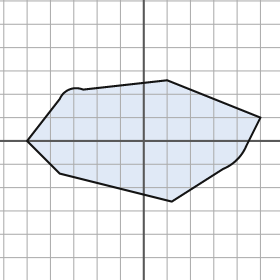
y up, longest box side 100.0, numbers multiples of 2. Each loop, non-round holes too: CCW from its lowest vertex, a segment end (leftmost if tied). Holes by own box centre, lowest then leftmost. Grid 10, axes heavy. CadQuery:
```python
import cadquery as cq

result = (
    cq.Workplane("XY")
    .moveTo(12.0, -26.0)
    .lineTo(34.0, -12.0)
    .threePointArc((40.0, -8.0), (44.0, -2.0))
    .lineTo(50.0, 10.0)
    .lineTo(10.0, 26.0)
    .lineTo(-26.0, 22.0)
    .threePointArc((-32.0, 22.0), (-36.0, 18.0))
    .lineTo(-50.0, 0.0)
    .lineTo(-36.0, -14.0)
    .close()
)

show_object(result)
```